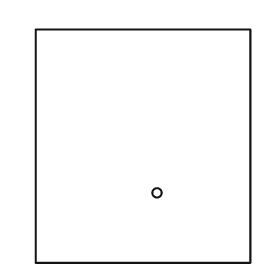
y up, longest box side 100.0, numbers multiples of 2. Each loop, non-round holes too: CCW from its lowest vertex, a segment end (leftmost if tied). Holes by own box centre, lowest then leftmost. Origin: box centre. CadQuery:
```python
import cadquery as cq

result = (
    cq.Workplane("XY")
    .moveTo(-46.0, -50.0)
    .lineTo(46.0, -50.0)
    .lineTo(46.0, 50.0)
    .lineTo(-46.0, 50.0)
    .close()
    .moveTo(6.0, -20.0)
    .circle(2.0)
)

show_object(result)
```